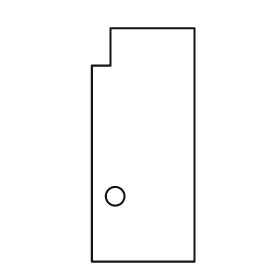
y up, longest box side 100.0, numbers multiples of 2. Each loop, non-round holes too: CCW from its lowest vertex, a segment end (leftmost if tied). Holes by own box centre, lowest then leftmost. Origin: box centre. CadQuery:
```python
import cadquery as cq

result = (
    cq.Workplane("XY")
    .moveTo(-22.0, -50.0)
    .lineTo(22.0, -50.0)
    .lineTo(22.0, 50.0)
    .lineTo(-14.0, 50.0)
    .lineTo(-14.0, 34.0)
    .lineTo(-22.0, 34.0)
    .close()
    .moveTo(-12.0, -22.0)
    .circle(4.0)
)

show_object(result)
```